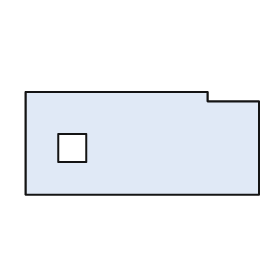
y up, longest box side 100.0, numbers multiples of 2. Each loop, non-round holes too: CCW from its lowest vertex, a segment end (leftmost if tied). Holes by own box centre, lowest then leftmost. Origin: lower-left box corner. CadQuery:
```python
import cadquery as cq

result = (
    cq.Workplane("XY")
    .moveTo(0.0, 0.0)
    .lineTo(100.0, 0.0)
    .lineTo(100.0, 40.0)
    .lineTo(78.0, 40.0)
    .lineTo(78.0, 44.0)
    .lineTo(0.0, 44.0)
    .close()
    .moveTo(14.0, 14.0)
    .lineTo(26.0, 14.0)
    .lineTo(26.0, 26.0)
    .lineTo(14.0, 26.0)
    .close()
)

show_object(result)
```